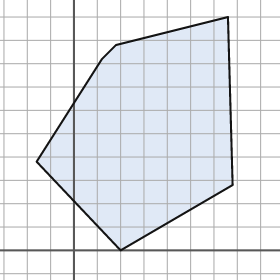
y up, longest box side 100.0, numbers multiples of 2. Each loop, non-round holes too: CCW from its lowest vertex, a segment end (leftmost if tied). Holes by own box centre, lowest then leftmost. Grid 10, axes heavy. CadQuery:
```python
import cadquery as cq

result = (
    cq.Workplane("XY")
    .moveTo(20.0, 0.0)
    .lineTo(68.0, 28.0)
    .lineTo(66.0, 100.0)
    .lineTo(18.0, 88.0)
    .lineTo(12.0, 82.0)
    .lineTo(-16.0, 38.0)
    .close()
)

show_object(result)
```